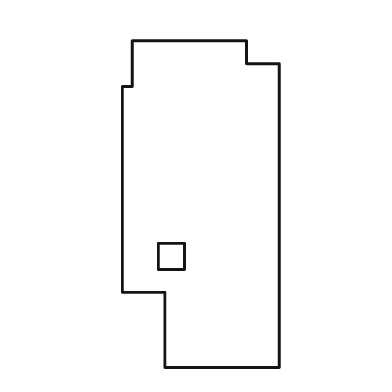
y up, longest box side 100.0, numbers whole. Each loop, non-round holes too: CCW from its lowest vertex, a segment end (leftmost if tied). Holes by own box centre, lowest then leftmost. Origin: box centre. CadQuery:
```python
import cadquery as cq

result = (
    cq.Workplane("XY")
    .moveTo(-11.0, -50.0)
    .lineTo(24.0, -50.0)
    .lineTo(24.0, 43.0)
    .lineTo(14.0, 43.0)
    .lineTo(14.0, 50.0)
    .lineTo(-21.0, 50.0)
    .lineTo(-21.0, 36.0)
    .lineTo(-24.0, 36.0)
    .lineTo(-24.0, -27.0)
    .lineTo(-11.0, -27.0)
    .close()
    .moveTo(-13.0, -20.0)
    .lineTo(-5.0, -20.0)
    .lineTo(-5.0, -12.0)
    .lineTo(-13.0, -12.0)
    .close()
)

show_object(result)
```